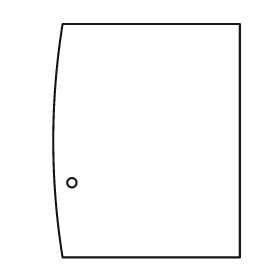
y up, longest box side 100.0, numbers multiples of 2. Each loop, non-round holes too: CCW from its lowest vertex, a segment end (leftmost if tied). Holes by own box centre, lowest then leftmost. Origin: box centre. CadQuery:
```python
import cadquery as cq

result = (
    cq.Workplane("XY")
    .moveTo(-36.0, -50.0)
    .lineTo(40.0, -50.0)
    .lineTo(40.0, 50.0)
    .lineTo(-36.0, 50.0)
    .threePointArc((-40.0, 0.0), (-36.0, -50.0))
    .close()
    .moveTo(-32.0, -18.0)
    .circle(2.0)
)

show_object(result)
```